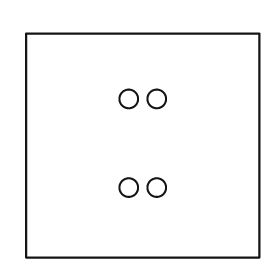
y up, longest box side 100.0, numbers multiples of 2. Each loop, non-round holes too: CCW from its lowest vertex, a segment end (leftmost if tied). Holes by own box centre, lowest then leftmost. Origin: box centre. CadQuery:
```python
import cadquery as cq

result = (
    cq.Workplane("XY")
    .moveTo(-50.0, -48.0)
    .lineTo(50.0, -48.0)
    .lineTo(50.0, 48.0)
    .lineTo(-50.0, 48.0)
    .close()
    .moveTo(-6.0, -18.0)
    .circle(4.0)
    .moveTo(6.0, -18.0)
    .circle(4.0)
    .moveTo(-6.0, 20.0)
    .circle(4.0)
    .moveTo(6.0, 20.0)
    .circle(4.0)
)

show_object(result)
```